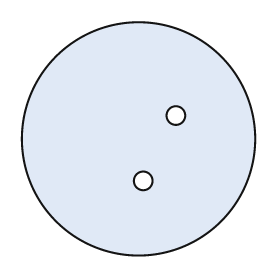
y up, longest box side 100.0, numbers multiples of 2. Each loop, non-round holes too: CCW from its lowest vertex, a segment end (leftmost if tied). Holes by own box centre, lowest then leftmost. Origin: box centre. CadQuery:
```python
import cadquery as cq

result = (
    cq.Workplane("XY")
    .moveTo(0.0, 0.0)
    .circle(50.0)
    .moveTo(2.0, -18.0)
    .circle(4.0)
    .moveTo(16.0, 10.0)
    .circle(4.0)
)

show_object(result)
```